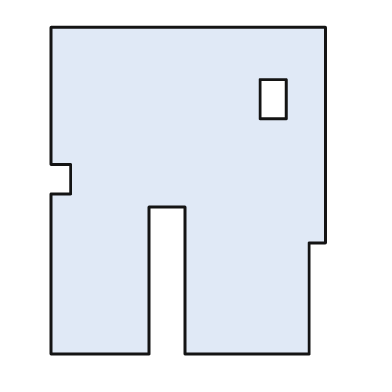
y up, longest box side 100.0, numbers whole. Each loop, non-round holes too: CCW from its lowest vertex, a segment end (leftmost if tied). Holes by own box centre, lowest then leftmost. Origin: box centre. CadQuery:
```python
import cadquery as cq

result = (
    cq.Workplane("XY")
    .moveTo(-42.0, -50.0)
    .lineTo(-12.0, -50.0)
    .lineTo(-12.0, -5.0)
    .lineTo(-1.0, -5.0)
    .lineTo(-1.0, -50.0)
    .lineTo(37.0, -50.0)
    .lineTo(37.0, -16.0)
    .lineTo(42.0, -16.0)
    .lineTo(42.0, 50.0)
    .lineTo(-42.0, 50.0)
    .lineTo(-42.0, 8.0)
    .lineTo(-36.0, 8.0)
    .lineTo(-36.0, -1.0)
    .lineTo(-42.0, -1.0)
    .close()
    .moveTo(22.0, 22.0)
    .lineTo(30.0, 22.0)
    .lineTo(30.0, 34.0)
    .lineTo(22.0, 34.0)
    .close()
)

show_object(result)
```